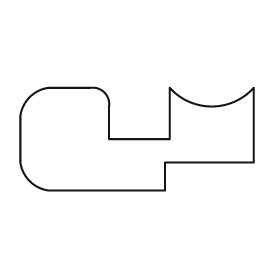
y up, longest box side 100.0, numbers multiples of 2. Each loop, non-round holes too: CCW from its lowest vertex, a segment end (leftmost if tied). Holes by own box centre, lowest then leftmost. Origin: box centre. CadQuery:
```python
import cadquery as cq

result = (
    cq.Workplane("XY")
    .moveTo(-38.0, -22.0)
    .lineTo(12.0, -22.0)
    .lineTo(12.0, -10.0)
    .lineTo(50.0, -10.0)
    .lineTo(50.0, 22.0)
    .threePointArc((32.0, 14.0), (14.0, 22.0))
    .lineTo(14.0, 0.0)
    .lineTo(-12.0, 0.0)
    .lineTo(-12.0, 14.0)
    .threePointArc((-14.0, 20.0), (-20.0, 22.0))
    .lineTo(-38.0, 22.0)
    .threePointArc((-46.0, 18.0), (-50.0, 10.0))
    .lineTo(-50.0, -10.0)
    .threePointArc((-46.0, -18.0), (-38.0, -22.0))
    .close()
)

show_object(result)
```